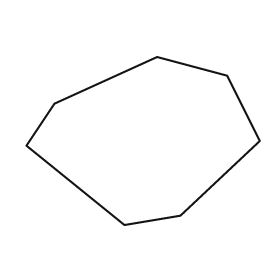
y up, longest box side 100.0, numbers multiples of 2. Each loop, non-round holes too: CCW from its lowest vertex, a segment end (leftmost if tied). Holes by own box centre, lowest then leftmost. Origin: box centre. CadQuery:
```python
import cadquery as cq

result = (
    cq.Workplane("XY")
    .moveTo(-8.0, -36.0)
    .lineTo(16.0, -32.0)
    .lineTo(50.0, 0.0)
    .lineTo(36.0, 28.0)
    .lineTo(6.0, 36.0)
    .lineTo(-38.0, 16.0)
    .lineTo(-50.0, -2.0)
    .close()
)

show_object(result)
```